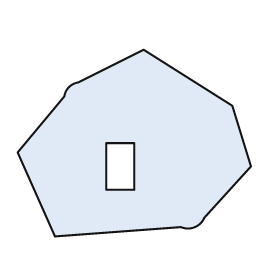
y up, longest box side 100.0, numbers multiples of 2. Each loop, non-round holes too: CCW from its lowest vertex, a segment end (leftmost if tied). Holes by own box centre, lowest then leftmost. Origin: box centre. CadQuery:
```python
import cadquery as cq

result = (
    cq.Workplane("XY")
    .moveTo(-34.0, -40.0)
    .lineTo(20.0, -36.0)
    .threePointArc((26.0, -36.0), (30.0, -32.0))
    .lineTo(50.0, -10.0)
    .lineTo(42.0, 16.0)
    .lineTo(4.0, 40.0)
    .lineTo(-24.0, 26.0)
    .threePointArc((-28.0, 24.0), (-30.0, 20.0))
    .lineTo(-50.0, -4.0)
    .close()
    .moveTo(-12.0, -20.0)
    .lineTo(0.0, -20.0)
    .lineTo(0.0, 0.0)
    .lineTo(-12.0, 0.0)
    .close()
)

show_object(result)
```